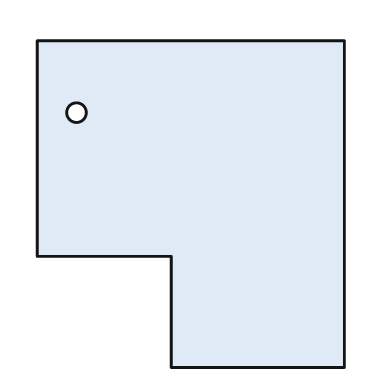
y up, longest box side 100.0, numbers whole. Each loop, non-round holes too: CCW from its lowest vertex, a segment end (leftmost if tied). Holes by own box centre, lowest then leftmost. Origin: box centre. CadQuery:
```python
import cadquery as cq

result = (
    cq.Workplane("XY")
    .moveTo(-6.0, -50.0)
    .lineTo(47.0, -50.0)
    .lineTo(47.0, 50.0)
    .lineTo(-47.0, 50.0)
    .lineTo(-47.0, -16.0)
    .lineTo(-6.0, -16.0)
    .close()
    .moveTo(-35.0, 28.0)
    .circle(3.0)
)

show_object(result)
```